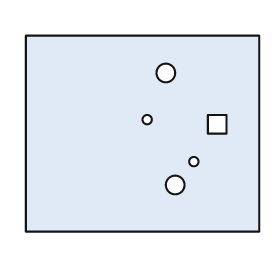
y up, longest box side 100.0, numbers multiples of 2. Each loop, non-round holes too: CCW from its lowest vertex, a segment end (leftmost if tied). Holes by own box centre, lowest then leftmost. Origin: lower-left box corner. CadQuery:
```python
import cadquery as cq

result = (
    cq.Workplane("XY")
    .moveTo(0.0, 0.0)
    .lineTo(100.0, 0.0)
    .lineTo(100.0, 84.0)
    .lineTo(0.0, 84.0)
    .close()
    .moveTo(64.0, 20.0)
    .circle(4.0)
    .moveTo(72.0, 30.0)
    .circle(2.0)
    .moveTo(78.0, 42.0)
    .lineTo(86.0, 42.0)
    .lineTo(86.0, 50.0)
    .lineTo(78.0, 50.0)
    .close()
    .moveTo(52.0, 48.0)
    .circle(2.0)
    .moveTo(60.0, 68.0)
    .circle(4.0)
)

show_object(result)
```